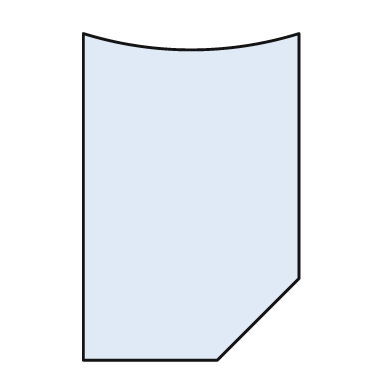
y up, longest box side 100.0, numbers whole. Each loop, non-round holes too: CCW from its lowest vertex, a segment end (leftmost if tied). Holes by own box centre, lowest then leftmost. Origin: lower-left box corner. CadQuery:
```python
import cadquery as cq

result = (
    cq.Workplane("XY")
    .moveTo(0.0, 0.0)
    .lineTo(41.0, 0.0)
    .lineTo(66.0, 25.0)
    .lineTo(66.0, 100.0)
    .threePointArc((33.0, 95.0), (0.0, 100.0))
    .close()
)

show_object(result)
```